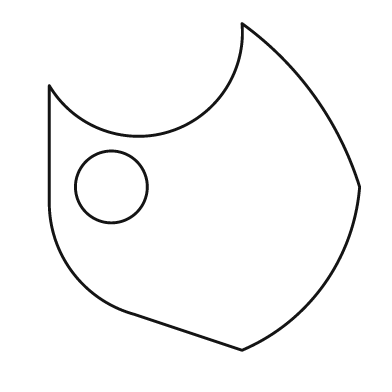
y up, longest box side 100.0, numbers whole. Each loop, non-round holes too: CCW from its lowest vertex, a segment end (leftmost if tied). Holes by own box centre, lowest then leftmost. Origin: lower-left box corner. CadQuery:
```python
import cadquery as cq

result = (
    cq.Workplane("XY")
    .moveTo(59.0, 0.0)
    .threePointArc((84.0, 20.0), (95.0, 50.0))
    .threePointArc((81.0, 78.0), (59.0, 100.0))
    .threePointArc((37.0, 67.0), (0.0, 81.0))
    .lineTo(0.0, 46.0)
    .threePointArc((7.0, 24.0), (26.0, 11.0))
    .close()
    .moveTo(19.0, 50.0)
    .circle(11.0)
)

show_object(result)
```